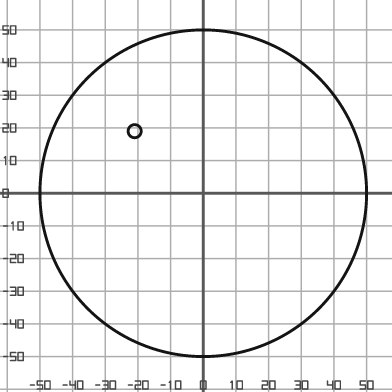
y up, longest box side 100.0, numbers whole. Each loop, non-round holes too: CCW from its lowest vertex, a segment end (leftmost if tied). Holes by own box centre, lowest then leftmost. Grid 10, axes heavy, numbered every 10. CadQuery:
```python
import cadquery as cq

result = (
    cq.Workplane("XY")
    .moveTo(0.0, 0.0)
    .circle(50.0)
    .moveTo(-21.0, 19.0)
    .circle(2.0)
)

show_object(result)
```